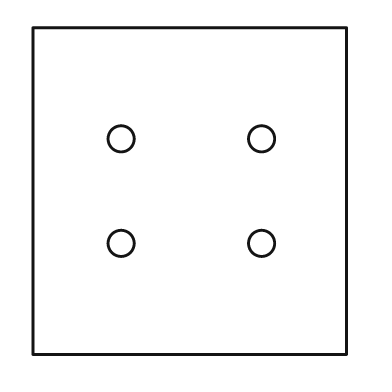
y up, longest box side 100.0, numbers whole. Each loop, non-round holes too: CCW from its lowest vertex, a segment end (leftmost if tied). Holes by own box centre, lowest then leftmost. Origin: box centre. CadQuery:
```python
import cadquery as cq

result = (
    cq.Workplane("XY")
    .moveTo(-48.0, -50.0)
    .lineTo(48.0, -50.0)
    .lineTo(48.0, 50.0)
    .lineTo(-48.0, 50.0)
    .close()
    .moveTo(-21.0, -16.0)
    .circle(4.0)
    .moveTo(22.0, -16.0)
    .circle(4.0)
    .moveTo(-21.0, 16.0)
    .circle(4.0)
    .moveTo(22.0, 16.0)
    .circle(4.0)
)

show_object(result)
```